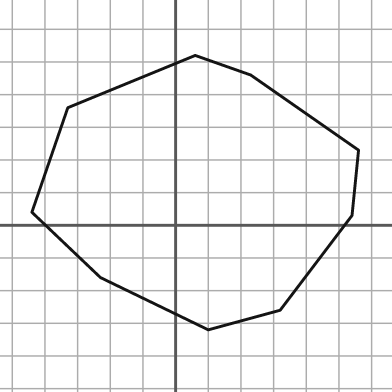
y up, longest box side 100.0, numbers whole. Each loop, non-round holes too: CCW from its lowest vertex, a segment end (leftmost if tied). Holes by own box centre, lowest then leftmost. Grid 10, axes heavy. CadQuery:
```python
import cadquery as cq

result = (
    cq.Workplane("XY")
    .moveTo(10.0, -32.0)
    .lineTo(32.0, -26.0)
    .lineTo(54.0, 3.0)
    .lineTo(56.0, 23.0)
    .lineTo(23.0, 46.0)
    .lineTo(6.0, 52.0)
    .lineTo(-33.0, 36.0)
    .lineTo(-44.0, 4.0)
    .lineTo(-23.0, -16.0)
    .close()
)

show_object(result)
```